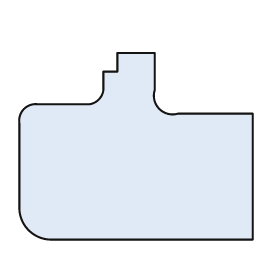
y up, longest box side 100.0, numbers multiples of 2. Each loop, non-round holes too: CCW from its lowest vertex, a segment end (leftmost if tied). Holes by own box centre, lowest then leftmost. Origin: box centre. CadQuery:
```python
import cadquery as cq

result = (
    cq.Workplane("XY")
    .moveTo(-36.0, -40.0)
    .lineTo(50.0, -40.0)
    .lineTo(50.0, 14.0)
    .lineTo(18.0, 14.0)
    .threePointArc((10.0, 16.0), (8.0, 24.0))
    .lineTo(8.0, 40.0)
    .lineTo(-8.0, 40.0)
    .lineTo(-8.0, 32.0)
    .lineTo(-14.0, 32.0)
    .lineTo(-14.0, 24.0)
    .threePointArc((-16.0, 20.0), (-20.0, 18.0))
    .lineTo(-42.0, 18.0)
    .threePointArc((-48.0, 16.0), (-50.0, 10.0))
    .lineTo(-50.0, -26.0)
    .threePointArc((-46.0, -36.0), (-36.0, -40.0))
    .close()
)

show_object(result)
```